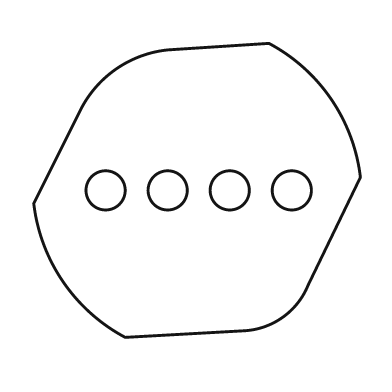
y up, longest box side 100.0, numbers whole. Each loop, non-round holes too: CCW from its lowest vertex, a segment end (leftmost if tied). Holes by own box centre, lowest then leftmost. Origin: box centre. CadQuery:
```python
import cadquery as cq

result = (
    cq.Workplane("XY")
    .moveTo(-22.0, -45.0)
    .lineTo(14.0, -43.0)
    .threePointArc((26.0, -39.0), (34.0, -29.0))
    .lineTo(50.0, 4.0)
    .threePointArc((41.0, 28.0), (22.0, 45.0))
    .lineTo(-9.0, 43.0)
    .threePointArc((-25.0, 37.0), (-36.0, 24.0))
    .lineTo(-50.0, -4.0)
    .threePointArc((-41.0, -28.0), (-22.0, -45.0))
    .close()
    .moveTo(-28.0, 0.0)
    .circle(6.0)
    .moveTo(-9.0, 0.0)
    .circle(6.0)
    .moveTo(10.0, 0.0)
    .circle(6.0)
    .moveTo(29.0, 0.0)
    .circle(6.0)
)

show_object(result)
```